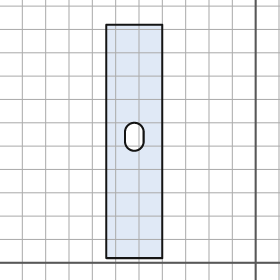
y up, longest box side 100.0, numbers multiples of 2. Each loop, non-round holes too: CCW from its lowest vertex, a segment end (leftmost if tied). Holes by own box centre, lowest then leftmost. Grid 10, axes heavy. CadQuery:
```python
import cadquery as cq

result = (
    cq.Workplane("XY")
    .moveTo(-64.0, 2.0)
    .lineTo(-40.0, 2.0)
    .lineTo(-40.0, 102.0)
    .lineTo(-64.0, 102.0)
    .close()
    .moveTo(-56.0, 52.0)
    .threePointArc((-52.0, 48.0), (-48.0, 52.0))
    .lineTo(-48.0, 56.0)
    .threePointArc((-52.0, 60.0), (-56.0, 56.0))
    .close()
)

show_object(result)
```